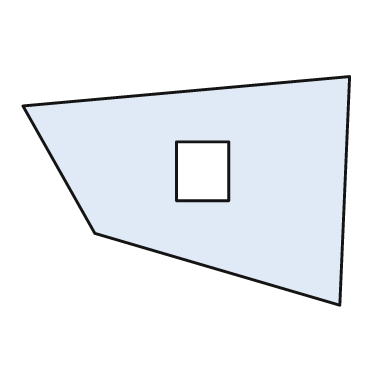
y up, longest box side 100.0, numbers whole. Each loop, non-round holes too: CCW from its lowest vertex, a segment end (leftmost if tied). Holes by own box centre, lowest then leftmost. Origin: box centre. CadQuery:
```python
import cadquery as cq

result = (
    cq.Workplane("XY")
    .moveTo(47.0, -35.0)
    .lineTo(50.0, 35.0)
    .lineTo(-50.0, 26.0)
    .lineTo(-28.0, -13.0)
    .close()
    .moveTo(-3.0, -3.0)
    .lineTo(13.0, -3.0)
    .lineTo(13.0, 15.0)
    .lineTo(-3.0, 15.0)
    .close()
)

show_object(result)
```